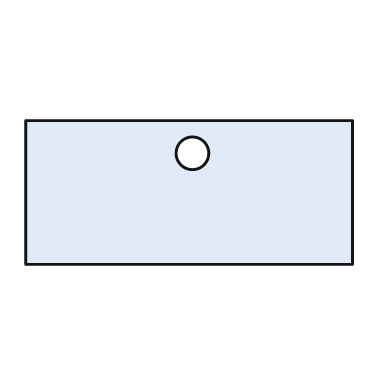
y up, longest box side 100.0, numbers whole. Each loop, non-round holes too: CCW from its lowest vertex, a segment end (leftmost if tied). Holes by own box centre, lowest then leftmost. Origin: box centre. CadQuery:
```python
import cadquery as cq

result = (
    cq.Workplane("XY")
    .moveTo(-50.0, -22.0)
    .lineTo(50.0, -22.0)
    .lineTo(50.0, 22.0)
    .lineTo(-50.0, 22.0)
    .close()
    .moveTo(1.0, 12.0)
    .circle(5.0)
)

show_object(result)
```